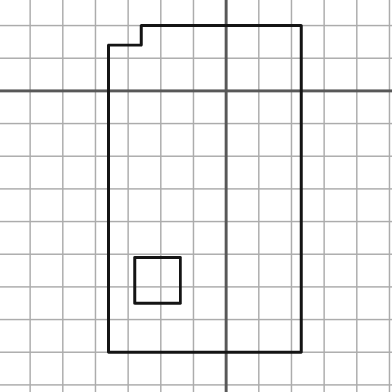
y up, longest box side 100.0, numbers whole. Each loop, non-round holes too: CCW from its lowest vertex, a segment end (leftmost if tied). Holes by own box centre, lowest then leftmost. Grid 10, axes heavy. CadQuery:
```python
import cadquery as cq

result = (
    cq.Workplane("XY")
    .moveTo(-36.0, -80.0)
    .lineTo(23.0, -80.0)
    .lineTo(23.0, 20.0)
    .lineTo(-26.0, 20.0)
    .lineTo(-26.0, 14.0)
    .lineTo(-36.0, 14.0)
    .close()
    .moveTo(-28.0, -65.0)
    .lineTo(-14.0, -65.0)
    .lineTo(-14.0, -51.0)
    .lineTo(-28.0, -51.0)
    .close()
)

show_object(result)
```